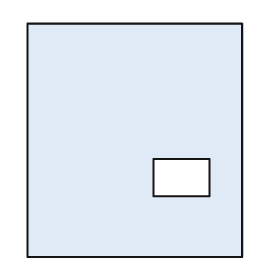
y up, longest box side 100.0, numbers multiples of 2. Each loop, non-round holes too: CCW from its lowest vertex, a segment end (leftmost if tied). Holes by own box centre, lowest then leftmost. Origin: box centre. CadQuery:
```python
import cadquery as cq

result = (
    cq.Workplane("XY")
    .moveTo(-46.0, -50.0)
    .lineTo(46.0, -50.0)
    .lineTo(46.0, 50.0)
    .lineTo(-46.0, 50.0)
    .close()
    .moveTo(8.0, -24.0)
    .lineTo(32.0, -24.0)
    .lineTo(32.0, -8.0)
    .lineTo(8.0, -8.0)
    .close()
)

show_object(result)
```